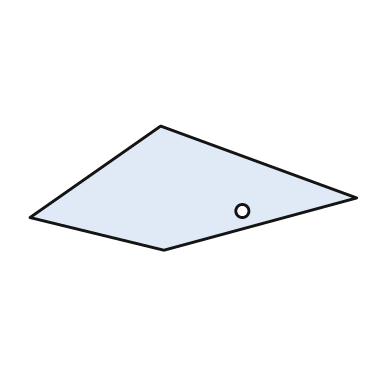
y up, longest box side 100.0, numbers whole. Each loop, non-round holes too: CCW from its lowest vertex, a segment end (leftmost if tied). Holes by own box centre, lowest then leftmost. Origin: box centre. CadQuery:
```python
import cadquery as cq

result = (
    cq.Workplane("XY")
    .moveTo(-9.0, -19.0)
    .lineTo(50.0, -3.0)
    .lineTo(-10.0, 19.0)
    .lineTo(-50.0, -9.0)
    .close()
    .moveTo(15.0, -7.0)
    .circle(2.0)
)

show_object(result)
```